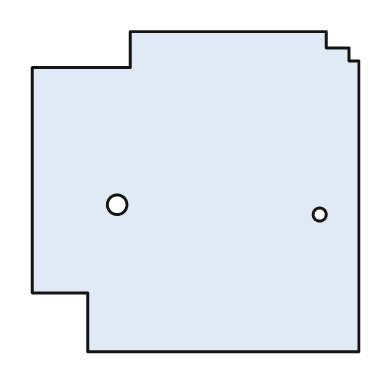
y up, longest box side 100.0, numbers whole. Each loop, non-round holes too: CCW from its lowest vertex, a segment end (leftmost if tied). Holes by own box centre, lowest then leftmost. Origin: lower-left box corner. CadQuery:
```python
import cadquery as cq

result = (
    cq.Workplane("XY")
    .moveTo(17.0, 0.0)
    .lineTo(100.0, 0.0)
    .lineTo(100.0, 89.0)
    .lineTo(97.0, 89.0)
    .lineTo(97.0, 93.0)
    .lineTo(90.0, 93.0)
    .lineTo(90.0, 98.0)
    .lineTo(30.0, 98.0)
    .lineTo(30.0, 87.0)
    .lineTo(0.0, 87.0)
    .lineTo(0.0, 18.0)
    .lineTo(17.0, 18.0)
    .close()
    .moveTo(88.0, 42.0)
    .circle(2.0)
    .moveTo(26.0, 45.0)
    .circle(3.0)
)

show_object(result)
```